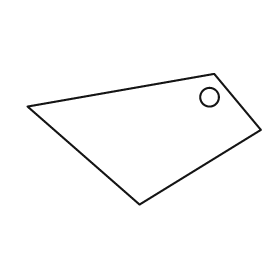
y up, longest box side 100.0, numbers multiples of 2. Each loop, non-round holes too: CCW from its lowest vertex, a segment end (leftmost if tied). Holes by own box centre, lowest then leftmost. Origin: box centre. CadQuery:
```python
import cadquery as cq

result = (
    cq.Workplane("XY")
    .moveTo(-2.0, -28.0)
    .lineTo(50.0, 4.0)
    .lineTo(30.0, 28.0)
    .lineTo(-50.0, 14.0)
    .close()
    .moveTo(28.0, 18.0)
    .circle(4.0)
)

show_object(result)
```